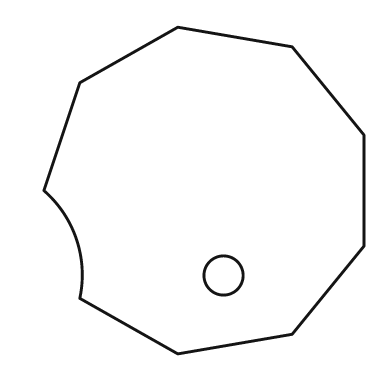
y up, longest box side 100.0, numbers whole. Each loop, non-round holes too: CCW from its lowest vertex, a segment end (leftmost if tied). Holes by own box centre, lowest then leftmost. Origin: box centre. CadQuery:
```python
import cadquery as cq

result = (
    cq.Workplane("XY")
    .moveTo(-8.0, -50.0)
    .lineTo(27.0, -44.0)
    .lineTo(49.0, -17.0)
    .lineTo(49.0, 17.0)
    .lineTo(27.0, 44.0)
    .lineTo(-8.0, 50.0)
    .lineTo(-38.0, 33.0)
    .lineTo(-49.0, 0.0)
    .threePointArc((-39.0, -15.0), (-38.0, -33.0))
    .close()
    .moveTo(6.0, -26.0)
    .circle(6.0)
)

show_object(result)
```